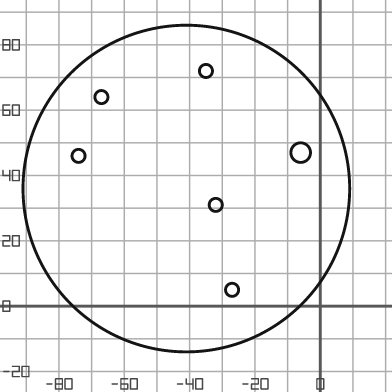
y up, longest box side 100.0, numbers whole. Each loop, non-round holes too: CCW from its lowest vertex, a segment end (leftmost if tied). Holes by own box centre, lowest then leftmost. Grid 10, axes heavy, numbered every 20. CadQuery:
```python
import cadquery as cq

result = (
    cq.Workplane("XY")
    .moveTo(-41.0, 36.0)
    .circle(50.0)
    .moveTo(-27.0, 5.0)
    .circle(2.0)
    .moveTo(-32.0, 31.0)
    .circle(2.0)
    .moveTo(-74.0, 46.0)
    .circle(2.0)
    .moveTo(-6.0, 47.0)
    .circle(3.0)
    .moveTo(-67.0, 64.0)
    .circle(2.0)
    .moveTo(-35.0, 72.0)
    .circle(2.0)
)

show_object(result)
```